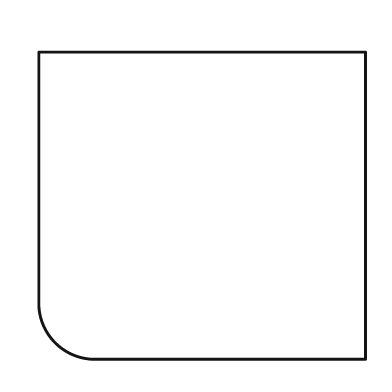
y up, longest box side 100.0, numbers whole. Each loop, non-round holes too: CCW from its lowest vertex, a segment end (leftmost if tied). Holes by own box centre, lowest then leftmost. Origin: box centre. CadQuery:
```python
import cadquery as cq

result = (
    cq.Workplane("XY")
    .moveTo(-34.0, -47.0)
    .lineTo(50.0, -47.0)
    .lineTo(50.0, 47.0)
    .lineTo(-50.0, 47.0)
    .lineTo(-50.0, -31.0)
    .threePointArc((-45.0, -42.0), (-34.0, -47.0))
    .close()
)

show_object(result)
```